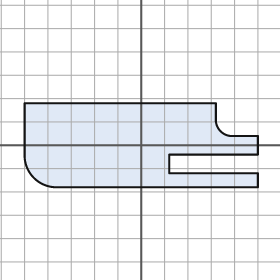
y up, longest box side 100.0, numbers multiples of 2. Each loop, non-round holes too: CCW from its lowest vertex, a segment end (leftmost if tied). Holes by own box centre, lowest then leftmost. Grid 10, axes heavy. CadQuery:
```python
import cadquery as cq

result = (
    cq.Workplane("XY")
    .moveTo(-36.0, -18.0)
    .lineTo(50.0, -18.0)
    .lineTo(50.0, -12.0)
    .lineTo(12.0, -12.0)
    .lineTo(12.0, -4.0)
    .lineTo(50.0, -4.0)
    .lineTo(50.0, 4.0)
    .lineTo(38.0, 4.0)
    .threePointArc((34.0, 6.0), (32.0, 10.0))
    .lineTo(32.0, 18.0)
    .lineTo(-50.0, 18.0)
    .lineTo(-50.0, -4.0)
    .threePointArc((-46.0, -14.0), (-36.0, -18.0))
    .close()
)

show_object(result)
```